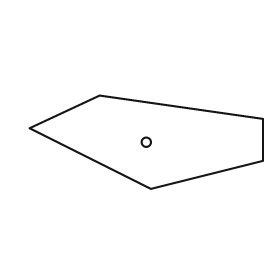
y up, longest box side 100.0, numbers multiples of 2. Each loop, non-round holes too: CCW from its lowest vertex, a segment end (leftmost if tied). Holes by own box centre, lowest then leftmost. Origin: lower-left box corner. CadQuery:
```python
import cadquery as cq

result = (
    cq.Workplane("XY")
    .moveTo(52.0, 0.0)
    .lineTo(100.0, 12.0)
    .lineTo(100.0, 30.0)
    .lineTo(30.0, 40.0)
    .lineTo(0.0, 26.0)
    .close()
    .moveTo(50.0, 20.0)
    .circle(2.0)
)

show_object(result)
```